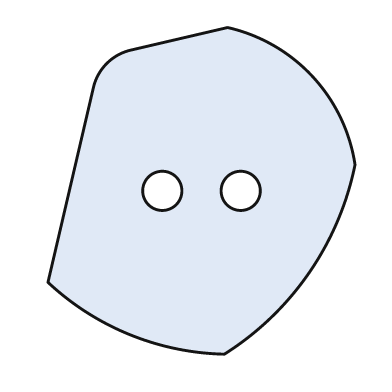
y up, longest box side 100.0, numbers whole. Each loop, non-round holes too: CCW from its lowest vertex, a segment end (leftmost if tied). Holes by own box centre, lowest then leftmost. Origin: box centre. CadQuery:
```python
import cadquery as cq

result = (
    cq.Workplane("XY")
    .moveTo(7.0, -50.0)
    .threePointArc((33.0, -25.0), (47.0, 8.0))
    .threePointArc((34.0, 35.0), (8.0, 50.0))
    .lineTo(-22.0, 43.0)
    .threePointArc((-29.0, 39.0), (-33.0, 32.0))
    .lineTo(-47.0, -28.0)
    .threePointArc((-22.0, -44.0), (7.0, -50.0))
    .close()
    .moveTo(-12.0, 0.0)
    .circle(6.0)
    .moveTo(12.0, 0.0)
    .circle(6.0)
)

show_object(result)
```